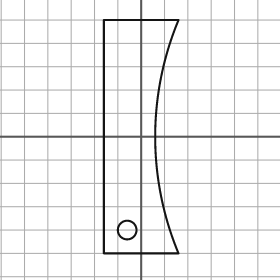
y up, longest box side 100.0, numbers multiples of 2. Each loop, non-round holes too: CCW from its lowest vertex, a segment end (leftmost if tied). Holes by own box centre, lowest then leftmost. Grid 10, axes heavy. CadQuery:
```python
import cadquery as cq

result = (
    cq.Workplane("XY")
    .moveTo(-16.0, -50.0)
    .lineTo(16.0, -50.0)
    .threePointArc((6.0, 0.0), (16.0, 50.0))
    .lineTo(-16.0, 50.0)
    .close()
    .moveTo(-6.0, -40.0)
    .circle(4.0)
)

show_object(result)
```